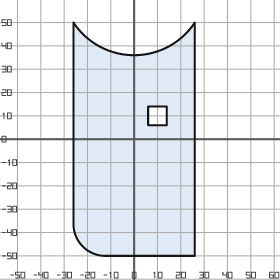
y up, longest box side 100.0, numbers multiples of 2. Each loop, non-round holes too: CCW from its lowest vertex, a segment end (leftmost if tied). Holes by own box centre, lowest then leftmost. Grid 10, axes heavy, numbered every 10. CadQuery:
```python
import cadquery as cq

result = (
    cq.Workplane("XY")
    .moveTo(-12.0, -50.0)
    .lineTo(26.0, -50.0)
    .lineTo(26.0, 50.0)
    .threePointArc((0.0, 36.0), (-26.0, 50.0))
    .lineTo(-26.0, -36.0)
    .threePointArc((-22.0, -46.0), (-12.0, -50.0))
    .close()
    .moveTo(6.0, 6.0)
    .lineTo(14.0, 6.0)
    .lineTo(14.0, 14.0)
    .lineTo(6.0, 14.0)
    .close()
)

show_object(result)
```